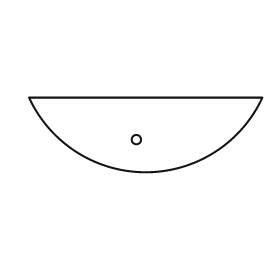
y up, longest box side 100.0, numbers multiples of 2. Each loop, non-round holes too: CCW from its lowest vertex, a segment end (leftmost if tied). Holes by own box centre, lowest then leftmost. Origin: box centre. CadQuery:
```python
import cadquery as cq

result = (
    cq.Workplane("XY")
    .moveTo(-50.0, 16.0)
    .threePointArc((0.0, -16.0), (50.0, 16.0))
    .close()
    .moveTo(-4.0, -2.0)
    .circle(2.0)
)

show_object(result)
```